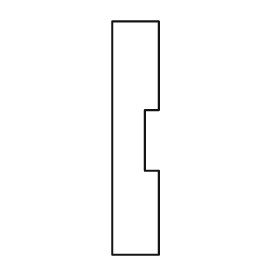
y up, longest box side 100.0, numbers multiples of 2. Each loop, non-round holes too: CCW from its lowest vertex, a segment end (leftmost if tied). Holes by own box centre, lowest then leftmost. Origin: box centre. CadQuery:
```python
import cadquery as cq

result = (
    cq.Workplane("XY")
    .moveTo(-10.0, -50.0)
    .lineTo(10.0, -50.0)
    .lineTo(10.0, -14.0)
    .lineTo(4.0, -14.0)
    .lineTo(4.0, 12.0)
    .lineTo(10.0, 12.0)
    .lineTo(10.0, 50.0)
    .lineTo(-10.0, 50.0)
    .close()
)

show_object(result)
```